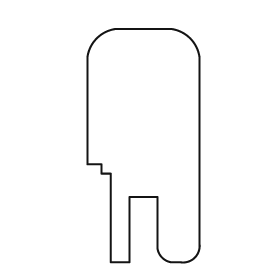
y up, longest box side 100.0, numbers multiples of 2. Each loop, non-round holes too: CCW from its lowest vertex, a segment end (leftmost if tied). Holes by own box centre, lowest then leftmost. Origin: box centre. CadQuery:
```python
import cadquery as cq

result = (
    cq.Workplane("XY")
    .moveTo(-14.0, -50.0)
    .lineTo(-6.0, -50.0)
    .lineTo(-6.0, -22.0)
    .lineTo(6.0, -22.0)
    .lineTo(6.0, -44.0)
    .threePointArc((8.0, -48.0), (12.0, -50.0))
    .lineTo(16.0, -50.0)
    .threePointArc((22.0, -48.0), (24.0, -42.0))
    .lineTo(24.0, 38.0)
    .threePointArc((20.0, 46.0), (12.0, 50.0))
    .lineTo(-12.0, 50.0)
    .threePointArc((-20.0, 46.0), (-24.0, 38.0))
    .lineTo(-24.0, -8.0)
    .lineTo(-18.0, -8.0)
    .lineTo(-18.0, -12.0)
    .lineTo(-14.0, -12.0)
    .close()
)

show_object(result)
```